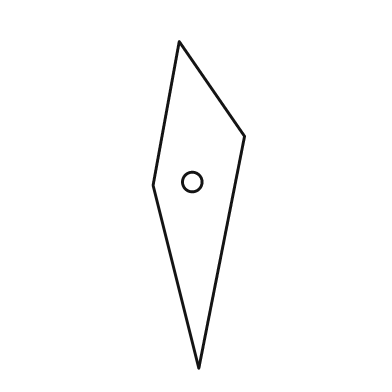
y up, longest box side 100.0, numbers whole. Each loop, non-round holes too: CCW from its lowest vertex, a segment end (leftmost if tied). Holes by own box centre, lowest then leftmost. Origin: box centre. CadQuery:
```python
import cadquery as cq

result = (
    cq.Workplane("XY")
    .moveTo(0.0, -50.0)
    .lineTo(14.0, 21.0)
    .lineTo(-6.0, 50.0)
    .lineTo(-14.0, 6.0)
    .close()
    .moveTo(-2.0, 7.0)
    .circle(3.0)
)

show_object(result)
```